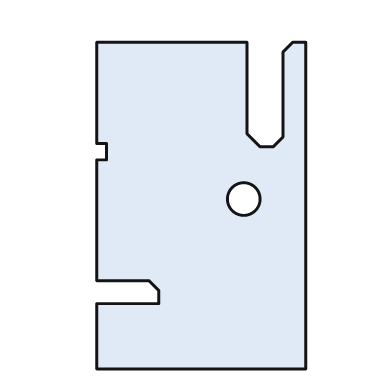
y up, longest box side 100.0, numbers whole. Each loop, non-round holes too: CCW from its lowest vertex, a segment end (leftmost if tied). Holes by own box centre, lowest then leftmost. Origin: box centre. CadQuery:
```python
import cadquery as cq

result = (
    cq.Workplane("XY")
    .moveTo(-32.0, -50.0)
    .lineTo(32.0, -50.0)
    .lineTo(32.0, 50.0)
    .lineTo(28.0, 50.0)
    .lineTo(25.0, 47.0)
    .lineTo(25.0, 21.0)
    .lineTo(22.0, 18.0)
    .lineTo(18.0, 18.0)
    .lineTo(14.0, 22.0)
    .lineTo(14.0, 50.0)
    .lineTo(-32.0, 50.0)
    .lineTo(-32.0, 19.0)
    .lineTo(-29.0, 19.0)
    .lineTo(-29.0, 14.0)
    .lineTo(-32.0, 14.0)
    .lineTo(-32.0, -23.0)
    .lineTo(-16.0, -23.0)
    .lineTo(-13.0, -26.0)
    .lineTo(-13.0, -30.0)
    .lineTo(-32.0, -30.0)
    .close()
    .moveTo(13.0, 2.0)
    .circle(5.0)
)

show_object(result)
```